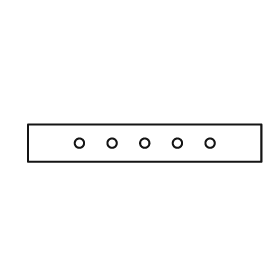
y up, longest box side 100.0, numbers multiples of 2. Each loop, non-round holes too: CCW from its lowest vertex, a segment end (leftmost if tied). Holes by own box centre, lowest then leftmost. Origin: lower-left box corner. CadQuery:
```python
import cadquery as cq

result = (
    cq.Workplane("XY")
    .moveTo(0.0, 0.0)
    .lineTo(100.0, 0.0)
    .lineTo(100.0, 16.0)
    .lineTo(0.0, 16.0)
    .close()
    .moveTo(22.0, 8.0)
    .circle(2.0)
    .moveTo(36.0, 8.0)
    .circle(2.0)
    .moveTo(50.0, 8.0)
    .circle(2.0)
    .moveTo(64.0, 8.0)
    .circle(2.0)
    .moveTo(78.0, 8.0)
    .circle(2.0)
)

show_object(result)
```